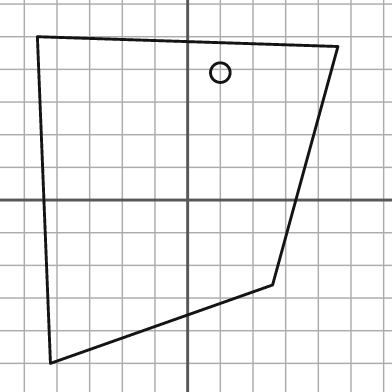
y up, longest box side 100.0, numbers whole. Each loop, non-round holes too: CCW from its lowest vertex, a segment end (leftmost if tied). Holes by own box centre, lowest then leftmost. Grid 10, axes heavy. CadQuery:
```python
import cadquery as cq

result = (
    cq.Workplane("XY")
    .moveTo(-42.0, -50.0)
    .lineTo(26.0, -26.0)
    .lineTo(46.0, 47.0)
    .lineTo(-46.0, 50.0)
    .close()
    .moveTo(10.0, 39.0)
    .circle(3.0)
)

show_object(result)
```